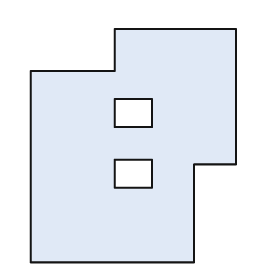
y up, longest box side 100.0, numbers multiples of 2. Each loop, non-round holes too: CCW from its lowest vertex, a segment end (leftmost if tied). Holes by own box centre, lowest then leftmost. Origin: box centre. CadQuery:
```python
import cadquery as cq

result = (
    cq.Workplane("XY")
    .moveTo(-44.0, -50.0)
    .lineTo(26.0, -50.0)
    .lineTo(26.0, -8.0)
    .lineTo(44.0, -8.0)
    .lineTo(44.0, 50.0)
    .lineTo(-8.0, 50.0)
    .lineTo(-8.0, 32.0)
    .lineTo(-44.0, 32.0)
    .close()
    .moveTo(-8.0, -18.0)
    .lineTo(8.0, -18.0)
    .lineTo(8.0, -6.0)
    .lineTo(-8.0, -6.0)
    .close()
    .moveTo(-8.0, 8.0)
    .lineTo(8.0, 8.0)
    .lineTo(8.0, 20.0)
    .lineTo(-8.0, 20.0)
    .close()
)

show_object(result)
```